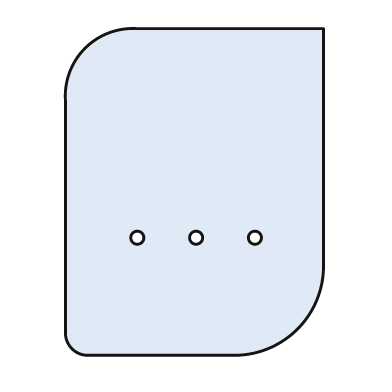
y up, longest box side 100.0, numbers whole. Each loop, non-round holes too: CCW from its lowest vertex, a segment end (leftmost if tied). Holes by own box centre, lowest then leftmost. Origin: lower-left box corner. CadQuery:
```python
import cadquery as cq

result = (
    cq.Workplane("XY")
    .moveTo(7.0, 0.0)
    .lineTo(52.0, 0.0)
    .threePointArc((71.0, 8.0), (79.0, 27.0))
    .lineTo(79.0, 100.0)
    .lineTo(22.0, 100.0)
    .threePointArc((6.0, 94.0), (0.0, 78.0))
    .lineTo(0.0, 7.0)
    .threePointArc((2.0, 2.0), (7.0, 0.0))
    .close()
    .moveTo(22.0, 36.0)
    .circle(2.0)
    .moveTo(40.0, 36.0)
    .circle(2.0)
    .moveTo(58.0, 36.0)
    .circle(2.0)
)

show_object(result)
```